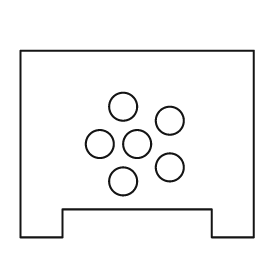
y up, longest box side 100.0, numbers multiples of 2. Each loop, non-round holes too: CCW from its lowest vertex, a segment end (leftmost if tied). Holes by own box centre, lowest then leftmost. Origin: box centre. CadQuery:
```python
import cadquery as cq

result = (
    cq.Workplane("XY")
    .moveTo(-50.0, -40.0)
    .lineTo(-32.0, -40.0)
    .lineTo(-32.0, -28.0)
    .lineTo(32.0, -28.0)
    .lineTo(32.0, -40.0)
    .lineTo(50.0, -40.0)
    .lineTo(50.0, 40.0)
    .lineTo(-50.0, 40.0)
    .close()
    .moveTo(-6.0, -16.0)
    .circle(6.0)
    .moveTo(14.0, -10.0)
    .circle(6.0)
    .moveTo(-16.0, 0.0)
    .circle(6.0)
    .moveTo(0.0, 0.0)
    .circle(6.0)
    .moveTo(14.0, 10.0)
    .circle(6.0)
    .moveTo(-6.0, 16.0)
    .circle(6.0)
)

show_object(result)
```